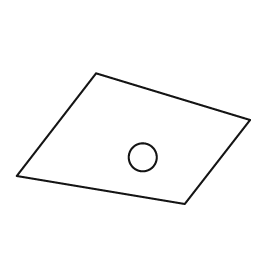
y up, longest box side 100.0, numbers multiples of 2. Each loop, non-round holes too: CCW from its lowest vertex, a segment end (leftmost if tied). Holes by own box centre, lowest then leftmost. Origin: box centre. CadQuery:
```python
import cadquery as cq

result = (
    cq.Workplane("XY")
    .moveTo(22.0, -28.0)
    .lineTo(50.0, 8.0)
    .lineTo(-16.0, 28.0)
    .lineTo(-50.0, -16.0)
    .close()
    .moveTo(4.0, -8.0)
    .circle(6.0)
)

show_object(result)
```